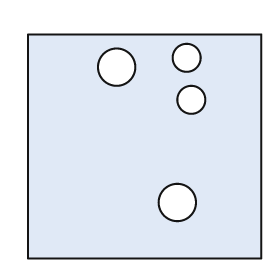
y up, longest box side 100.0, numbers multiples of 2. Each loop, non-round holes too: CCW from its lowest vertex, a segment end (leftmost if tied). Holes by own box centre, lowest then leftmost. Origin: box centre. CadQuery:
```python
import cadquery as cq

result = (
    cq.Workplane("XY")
    .moveTo(-50.0, -48.0)
    .lineTo(50.0, -48.0)
    .lineTo(50.0, 48.0)
    .lineTo(-50.0, 48.0)
    .close()
    .moveTo(14.0, -24.0)
    .circle(8.0)
    .moveTo(20.0, 20.0)
    .circle(6.0)
    .moveTo(-12.0, 34.0)
    .circle(8.0)
    .moveTo(18.0, 38.0)
    .circle(6.0)
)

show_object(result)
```